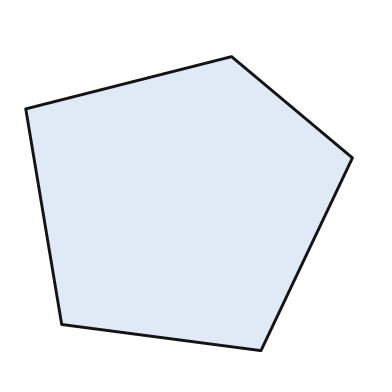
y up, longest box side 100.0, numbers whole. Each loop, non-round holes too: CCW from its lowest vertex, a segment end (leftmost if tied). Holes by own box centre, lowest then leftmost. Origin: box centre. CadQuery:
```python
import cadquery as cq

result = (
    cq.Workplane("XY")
    .moveTo(22.0, -45.0)
    .lineTo(50.0, 14.0)
    .lineTo(13.0, 45.0)
    .lineTo(-50.0, 29.0)
    .lineTo(-39.0, -37.0)
    .close()
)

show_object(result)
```